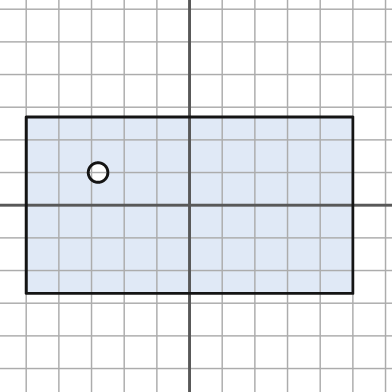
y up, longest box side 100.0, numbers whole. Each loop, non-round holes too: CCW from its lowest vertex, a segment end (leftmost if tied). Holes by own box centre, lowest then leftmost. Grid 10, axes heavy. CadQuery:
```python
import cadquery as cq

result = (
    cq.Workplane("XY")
    .moveTo(-50.0, -27.0)
    .lineTo(50.0, -27.0)
    .lineTo(50.0, 27.0)
    .lineTo(-50.0, 27.0)
    .close()
    .moveTo(-28.0, 10.0)
    .circle(3.0)
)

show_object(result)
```